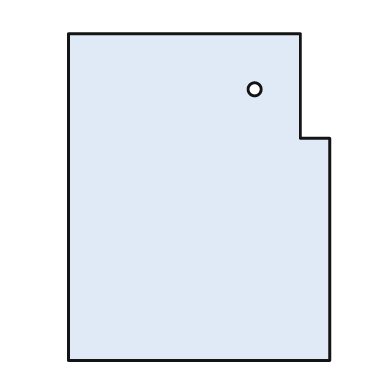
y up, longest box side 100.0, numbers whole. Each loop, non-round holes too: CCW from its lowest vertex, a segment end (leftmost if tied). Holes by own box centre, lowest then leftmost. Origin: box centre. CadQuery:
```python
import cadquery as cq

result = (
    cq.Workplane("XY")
    .moveTo(-40.0, -50.0)
    .lineTo(40.0, -50.0)
    .lineTo(40.0, 18.0)
    .lineTo(31.0, 18.0)
    .lineTo(31.0, 50.0)
    .lineTo(-40.0, 50.0)
    .close()
    .moveTo(17.0, 33.0)
    .circle(2.0)
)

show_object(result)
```